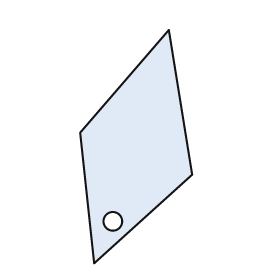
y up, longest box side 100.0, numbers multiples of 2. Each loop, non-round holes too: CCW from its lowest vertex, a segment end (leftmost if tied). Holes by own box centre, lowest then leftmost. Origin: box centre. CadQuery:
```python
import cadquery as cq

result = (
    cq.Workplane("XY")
    .moveTo(-18.0, -50.0)
    .lineTo(24.0, -12.0)
    .lineTo(14.0, 50.0)
    .lineTo(-24.0, 6.0)
    .close()
    .moveTo(-10.0, -32.0)
    .circle(4.0)
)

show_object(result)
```